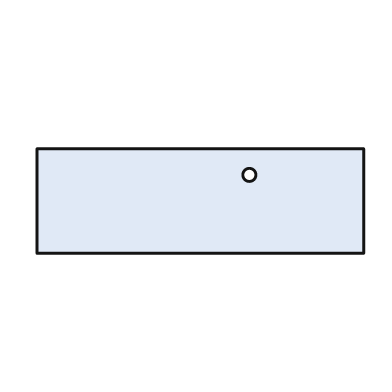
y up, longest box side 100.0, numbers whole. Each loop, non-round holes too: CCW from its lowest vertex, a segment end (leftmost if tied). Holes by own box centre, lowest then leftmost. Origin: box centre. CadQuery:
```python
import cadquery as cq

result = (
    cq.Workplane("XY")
    .moveTo(-50.0, -16.0)
    .lineTo(50.0, -16.0)
    .lineTo(50.0, 16.0)
    .lineTo(-50.0, 16.0)
    .close()
    .moveTo(15.0, 8.0)
    .circle(2.0)
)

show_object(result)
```